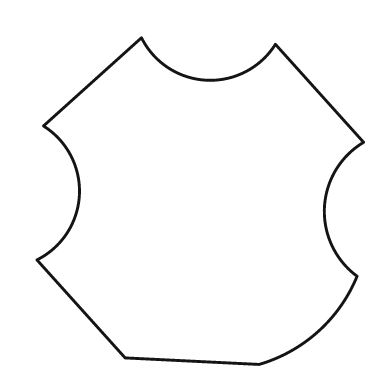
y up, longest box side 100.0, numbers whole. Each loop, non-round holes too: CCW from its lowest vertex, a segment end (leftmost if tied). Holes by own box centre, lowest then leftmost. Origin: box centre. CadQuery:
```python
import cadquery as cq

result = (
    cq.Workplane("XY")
    .moveTo(18.0, -50.0)
    .threePointArc((36.0, -40.0), (48.0, -23.0))
    .threePointArc((38.0, -2.0), (50.0, 18.0))
    .lineTo(23.0, 48.0)
    .threePointArc((2.0, 37.0), (-18.0, 50.0))
    .lineTo(-48.0, 23.0)
    .threePointArc((-37.0, 2.0), (-50.0, -18.0))
    .lineTo(-23.0, -48.0)
    .close()
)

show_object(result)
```